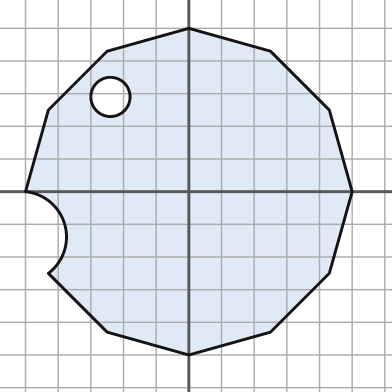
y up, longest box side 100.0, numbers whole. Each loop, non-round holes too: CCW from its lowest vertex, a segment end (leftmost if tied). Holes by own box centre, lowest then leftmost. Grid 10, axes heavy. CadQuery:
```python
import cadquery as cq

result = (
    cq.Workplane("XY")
    .moveTo(0.0, -50.0)
    .lineTo(25.0, -43.0)
    .lineTo(43.0, -25.0)
    .lineTo(50.0, 0.0)
    .lineTo(43.0, 25.0)
    .lineTo(25.0, 43.0)
    .lineTo(0.0, 50.0)
    .lineTo(-25.0, 43.0)
    .lineTo(-43.0, 25.0)
    .lineTo(-50.0, 0.0)
    .threePointArc((-38.0, -10.0), (-43.0, -25.0))
    .lineTo(-25.0, -43.0)
    .close()
    .moveTo(-24.0, 29.0)
    .circle(6.0)
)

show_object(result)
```